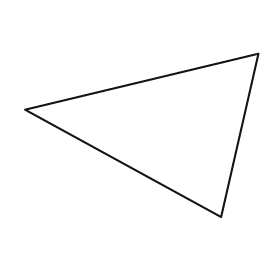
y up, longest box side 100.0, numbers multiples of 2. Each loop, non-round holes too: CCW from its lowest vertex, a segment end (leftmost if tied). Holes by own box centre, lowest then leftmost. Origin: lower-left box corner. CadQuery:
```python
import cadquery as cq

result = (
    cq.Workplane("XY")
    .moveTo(84.0, 0.0)
    .lineTo(100.0, 70.0)
    .lineTo(0.0, 46.0)
    .close()
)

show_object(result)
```